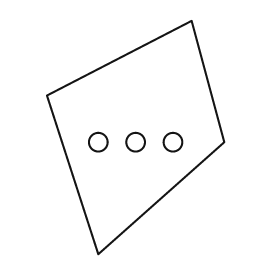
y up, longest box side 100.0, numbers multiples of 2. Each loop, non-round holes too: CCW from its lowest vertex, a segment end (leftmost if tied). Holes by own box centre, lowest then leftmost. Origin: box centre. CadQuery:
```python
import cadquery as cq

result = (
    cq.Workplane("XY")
    .moveTo(-16.0, -50.0)
    .lineTo(38.0, -2.0)
    .lineTo(24.0, 50.0)
    .lineTo(-38.0, 18.0)
    .close()
    .moveTo(-16.0, -2.0)
    .circle(4.0)
    .moveTo(0.0, -2.0)
    .circle(4.0)
    .moveTo(16.0, -2.0)
    .circle(4.0)
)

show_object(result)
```